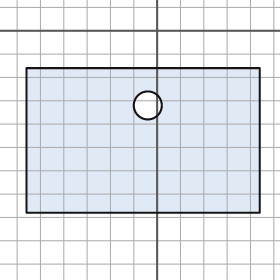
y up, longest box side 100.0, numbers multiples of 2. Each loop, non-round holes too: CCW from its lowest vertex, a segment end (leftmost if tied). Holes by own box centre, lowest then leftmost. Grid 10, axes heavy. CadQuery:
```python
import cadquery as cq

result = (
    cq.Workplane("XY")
    .moveTo(-56.0, -78.0)
    .lineTo(44.0, -78.0)
    .lineTo(44.0, -16.0)
    .lineTo(-56.0, -16.0)
    .close()
    .moveTo(-4.0, -32.0)
    .circle(6.0)
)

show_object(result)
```